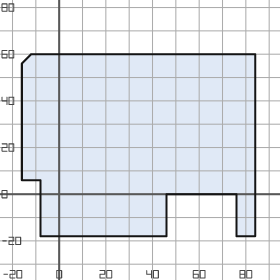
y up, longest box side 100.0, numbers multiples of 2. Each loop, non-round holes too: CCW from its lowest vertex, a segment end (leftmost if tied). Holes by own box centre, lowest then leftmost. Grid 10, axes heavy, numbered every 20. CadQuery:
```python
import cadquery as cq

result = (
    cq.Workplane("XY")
    .moveTo(-8.0, -18.0)
    .lineTo(46.0, -18.0)
    .lineTo(46.0, 0.0)
    .lineTo(76.0, 0.0)
    .lineTo(76.0, -18.0)
    .lineTo(84.0, -18.0)
    .lineTo(84.0, 60.0)
    .lineTo(-12.0, 60.0)
    .lineTo(-16.0, 56.0)
    .lineTo(-16.0, 6.0)
    .lineTo(-8.0, 6.0)
    .close()
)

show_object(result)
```